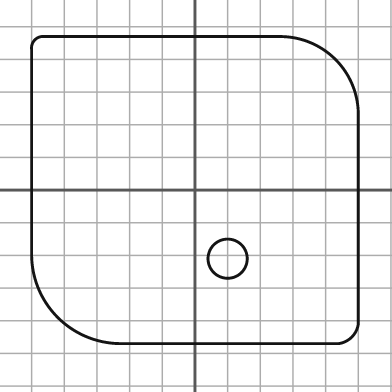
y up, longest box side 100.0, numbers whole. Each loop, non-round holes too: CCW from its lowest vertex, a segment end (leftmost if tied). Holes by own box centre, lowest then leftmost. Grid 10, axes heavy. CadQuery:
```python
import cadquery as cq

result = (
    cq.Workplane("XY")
    .moveTo(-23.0, -47.0)
    .lineTo(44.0, -47.0)
    .threePointArc((48.0, -45.0), (50.0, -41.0))
    .lineTo(50.0, 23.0)
    .threePointArc((43.0, 40.0), (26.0, 47.0))
    .lineTo(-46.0, 47.0)
    .threePointArc((-49.0, 46.0), (-50.0, 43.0))
    .lineTo(-50.0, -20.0)
    .threePointArc((-42.0, -39.0), (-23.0, -47.0))
    .close()
    .moveTo(10.0, -21.0)
    .circle(6.0)
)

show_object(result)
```